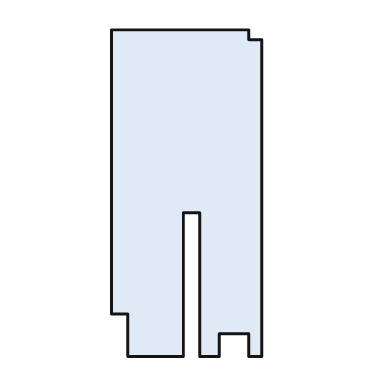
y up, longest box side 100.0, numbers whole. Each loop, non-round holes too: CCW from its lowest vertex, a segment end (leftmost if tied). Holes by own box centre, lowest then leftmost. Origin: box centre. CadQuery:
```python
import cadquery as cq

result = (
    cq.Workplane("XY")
    .moveTo(-18.0, -50.0)
    .lineTo(-1.0, -50.0)
    .lineTo(-1.0, -6.0)
    .lineTo(4.0, -6.0)
    .lineTo(4.0, -50.0)
    .lineTo(10.0, -50.0)
    .lineTo(10.0, -43.0)
    .lineTo(19.0, -43.0)
    .lineTo(19.0, -50.0)
    .lineTo(23.0, -50.0)
    .lineTo(23.0, 47.0)
    .lineTo(19.0, 47.0)
    .lineTo(19.0, 50.0)
    .lineTo(-23.0, 50.0)
    .lineTo(-23.0, -37.0)
    .lineTo(-18.0, -37.0)
    .close()
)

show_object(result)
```